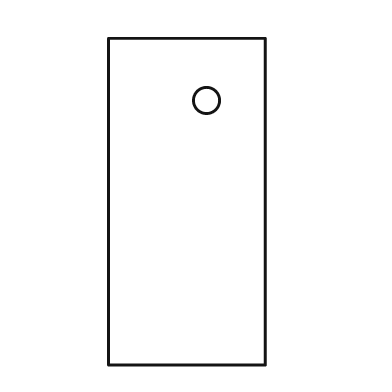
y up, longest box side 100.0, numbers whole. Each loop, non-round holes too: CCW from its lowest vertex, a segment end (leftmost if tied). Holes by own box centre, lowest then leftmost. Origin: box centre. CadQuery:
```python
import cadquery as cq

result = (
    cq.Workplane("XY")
    .moveTo(-24.0, -50.0)
    .lineTo(24.0, -50.0)
    .lineTo(24.0, 50.0)
    .lineTo(-24.0, 50.0)
    .close()
    .moveTo(6.0, 31.0)
    .circle(4.0)
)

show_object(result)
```